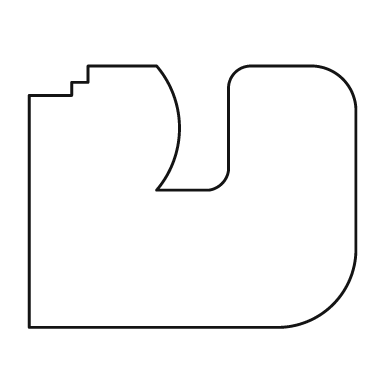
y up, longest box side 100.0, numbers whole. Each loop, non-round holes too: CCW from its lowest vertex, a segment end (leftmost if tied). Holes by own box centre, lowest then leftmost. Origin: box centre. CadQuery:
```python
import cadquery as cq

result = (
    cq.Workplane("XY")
    .moveTo(-50.0, -40.0)
    .lineTo(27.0, -40.0)
    .threePointArc((43.0, -33.0), (50.0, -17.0))
    .lineTo(50.0, 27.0)
    .threePointArc((46.0, 36.0), (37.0, 40.0))
    .lineTo(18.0, 40.0)
    .threePointArc((13.0, 38.0), (11.0, 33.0))
    .lineTo(11.0, 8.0)
    .threePointArc((9.0, 4.0), (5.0, 2.0))
    .lineTo(-11.0, 2.0)
    .threePointArc((-4.0, 21.0), (-11.0, 40.0))
    .lineTo(-32.0, 40.0)
    .lineTo(-32.0, 35.0)
    .lineTo(-37.0, 35.0)
    .lineTo(-37.0, 31.0)
    .lineTo(-50.0, 31.0)
    .close()
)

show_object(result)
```